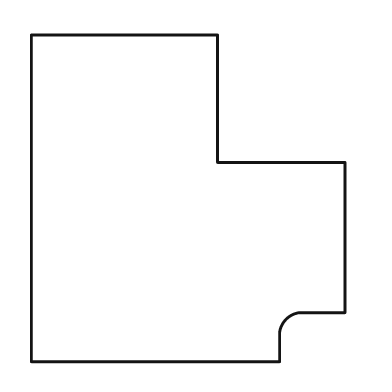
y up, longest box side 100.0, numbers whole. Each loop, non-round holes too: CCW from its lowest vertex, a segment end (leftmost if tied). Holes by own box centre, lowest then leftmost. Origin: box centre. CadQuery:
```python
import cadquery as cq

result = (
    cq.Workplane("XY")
    .moveTo(-48.0, -50.0)
    .lineTo(28.0, -50.0)
    .lineTo(28.0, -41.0)
    .threePointArc((30.0, -37.0), (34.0, -35.0))
    .lineTo(48.0, -35.0)
    .lineTo(48.0, 11.0)
    .lineTo(9.0, 11.0)
    .lineTo(9.0, 50.0)
    .lineTo(-48.0, 50.0)
    .close()
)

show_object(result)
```